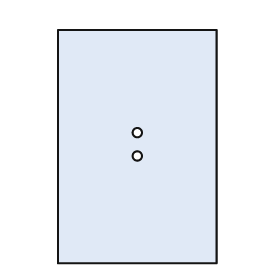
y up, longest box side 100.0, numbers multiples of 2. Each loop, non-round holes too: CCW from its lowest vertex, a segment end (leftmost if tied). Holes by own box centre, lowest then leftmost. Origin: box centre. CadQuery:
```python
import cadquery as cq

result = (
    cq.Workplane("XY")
    .moveTo(-34.0, -50.0)
    .lineTo(34.0, -50.0)
    .lineTo(34.0, 50.0)
    .lineTo(-34.0, 50.0)
    .close()
    .moveTo(0.0, -4.0)
    .circle(2.0)
    .moveTo(0.0, 6.0)
    .circle(2.0)
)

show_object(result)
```